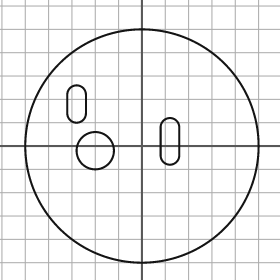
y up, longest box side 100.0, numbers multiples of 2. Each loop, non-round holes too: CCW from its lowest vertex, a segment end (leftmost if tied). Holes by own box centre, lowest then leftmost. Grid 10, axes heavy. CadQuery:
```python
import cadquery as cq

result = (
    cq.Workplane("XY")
    .moveTo(0.0, 0.0)
    .circle(50.0)
    .moveTo(-20.0, -2.0)
    .circle(8.0)
    .moveTo(8.0, -4.0)
    .threePointArc((12.0, -8.0), (16.0, -4.0))
    .lineTo(16.0, 8.0)
    .threePointArc((12.0, 12.0), (8.0, 8.0))
    .close()
    .moveTo(-32.0, 14.0)
    .threePointArc((-28.0, 10.0), (-24.0, 14.0))
    .lineTo(-24.0, 22.0)
    .threePointArc((-28.0, 26.0), (-32.0, 22.0))
    .close()
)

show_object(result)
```